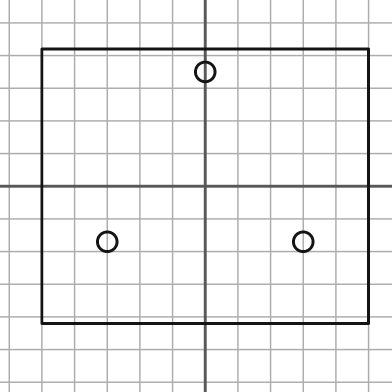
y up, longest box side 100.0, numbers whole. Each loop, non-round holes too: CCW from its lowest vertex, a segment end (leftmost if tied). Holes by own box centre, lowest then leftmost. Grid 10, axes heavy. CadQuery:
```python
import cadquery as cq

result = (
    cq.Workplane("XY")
    .moveTo(-50.0, -42.0)
    .lineTo(50.0, -42.0)
    .lineTo(50.0, 42.0)
    .lineTo(-50.0, 42.0)
    .close()
    .moveTo(-30.0, -17.0)
    .circle(3.0)
    .moveTo(30.0, -17.0)
    .circle(3.0)
    .moveTo(0.0, 35.0)
    .circle(3.0)
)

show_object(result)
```